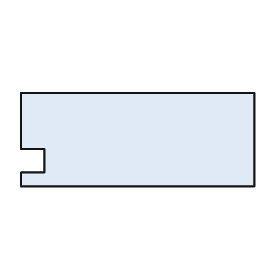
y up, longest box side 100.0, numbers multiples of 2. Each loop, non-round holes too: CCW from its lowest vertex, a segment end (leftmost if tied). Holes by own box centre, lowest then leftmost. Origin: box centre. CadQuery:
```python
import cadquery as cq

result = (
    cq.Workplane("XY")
    .moveTo(-50.0, -20.0)
    .lineTo(50.0, -20.0)
    .lineTo(50.0, 20.0)
    .lineTo(-50.0, 20.0)
    .lineTo(-50.0, -4.0)
    .lineTo(-40.0, -4.0)
    .lineTo(-40.0, -14.0)
    .lineTo(-50.0, -14.0)
    .close()
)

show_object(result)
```